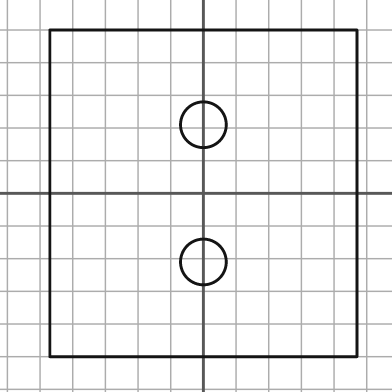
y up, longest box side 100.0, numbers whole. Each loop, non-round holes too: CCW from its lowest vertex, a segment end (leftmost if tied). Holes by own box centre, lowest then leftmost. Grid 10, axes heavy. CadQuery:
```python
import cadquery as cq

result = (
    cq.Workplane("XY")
    .moveTo(-47.0, -50.0)
    .lineTo(47.0, -50.0)
    .lineTo(47.0, 50.0)
    .lineTo(-47.0, 50.0)
    .close()
    .moveTo(0.0, -21.0)
    .circle(7.0)
    .moveTo(0.0, 21.0)
    .circle(7.0)
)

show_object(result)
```